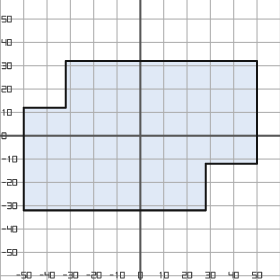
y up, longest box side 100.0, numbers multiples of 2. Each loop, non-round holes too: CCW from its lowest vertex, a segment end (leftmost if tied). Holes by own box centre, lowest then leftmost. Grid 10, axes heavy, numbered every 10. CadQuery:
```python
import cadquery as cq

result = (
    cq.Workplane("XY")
    .moveTo(-50.0, -32.0)
    .lineTo(28.0, -32.0)
    .lineTo(28.0, -12.0)
    .lineTo(50.0, -12.0)
    .lineTo(50.0, 32.0)
    .lineTo(-32.0, 32.0)
    .lineTo(-32.0, 12.0)
    .lineTo(-50.0, 12.0)
    .close()
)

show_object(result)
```